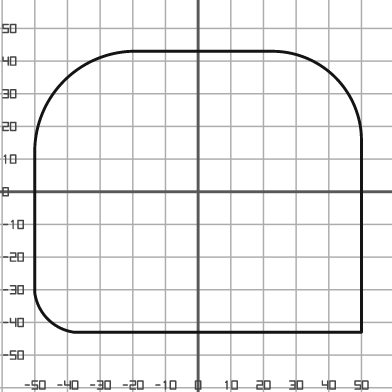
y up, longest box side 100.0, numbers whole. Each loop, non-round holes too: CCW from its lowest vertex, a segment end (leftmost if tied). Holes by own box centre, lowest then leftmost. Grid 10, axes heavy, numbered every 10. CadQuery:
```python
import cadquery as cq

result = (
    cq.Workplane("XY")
    .moveTo(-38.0, -43.0)
    .lineTo(50.0, -43.0)
    .lineTo(50.0, 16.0)
    .threePointArc((42.0, 35.0), (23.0, 43.0))
    .lineTo(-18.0, 43.0)
    .threePointArc((-41.0, 34.0), (-50.0, 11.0))
    .lineTo(-50.0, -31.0)
    .threePointArc((-46.0, -39.0), (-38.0, -43.0))
    .close()
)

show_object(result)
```